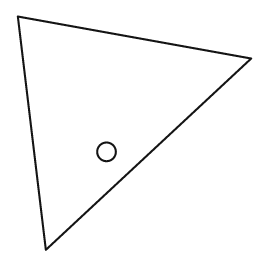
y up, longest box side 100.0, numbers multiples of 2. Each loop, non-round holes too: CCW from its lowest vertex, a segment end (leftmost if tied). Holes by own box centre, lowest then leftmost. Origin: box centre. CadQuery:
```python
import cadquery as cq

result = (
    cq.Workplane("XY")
    .moveTo(-38.0, -50.0)
    .lineTo(50.0, 32.0)
    .lineTo(-50.0, 50.0)
    .close()
    .moveTo(-12.0, -8.0)
    .circle(4.0)
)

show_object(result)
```